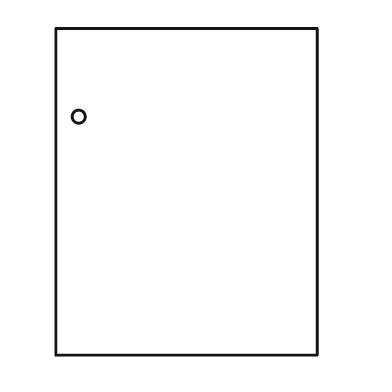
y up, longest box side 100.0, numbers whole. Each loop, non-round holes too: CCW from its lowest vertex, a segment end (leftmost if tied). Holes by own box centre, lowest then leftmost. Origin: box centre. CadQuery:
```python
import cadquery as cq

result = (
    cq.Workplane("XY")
    .moveTo(-40.0, -50.0)
    .lineTo(40.0, -50.0)
    .lineTo(40.0, 50.0)
    .lineTo(-40.0, 50.0)
    .close()
    .moveTo(-33.0, 23.0)
    .circle(2.0)
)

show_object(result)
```